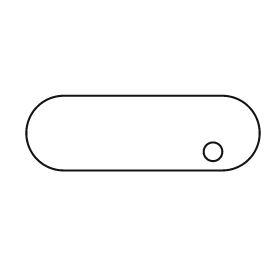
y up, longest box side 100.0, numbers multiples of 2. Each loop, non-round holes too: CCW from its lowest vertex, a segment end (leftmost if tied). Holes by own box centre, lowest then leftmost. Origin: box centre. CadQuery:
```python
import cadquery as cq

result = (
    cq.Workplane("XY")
    .moveTo(-34.0, -16.0)
    .lineTo(34.0, -16.0)
    .threePointArc((50.0, 0.0), (34.0, 16.0))
    .lineTo(-34.0, 16.0)
    .threePointArc((-50.0, 0.0), (-34.0, -16.0))
    .close()
    .moveTo(30.0, -8.0)
    .circle(4.0)
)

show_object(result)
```